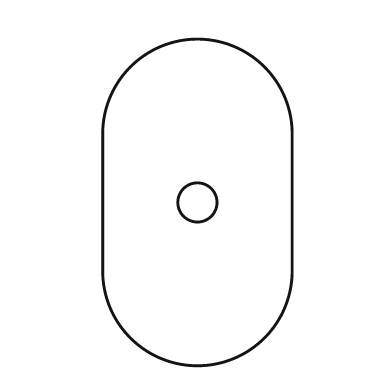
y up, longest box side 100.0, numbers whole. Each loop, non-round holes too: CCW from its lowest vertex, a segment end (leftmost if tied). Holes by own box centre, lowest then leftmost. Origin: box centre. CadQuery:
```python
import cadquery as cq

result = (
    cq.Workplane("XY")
    .moveTo(-29.0, -21.0)
    .threePointArc((0.0, -50.0), (29.0, -21.0))
    .lineTo(29.0, 21.0)
    .threePointArc((0.0, 50.0), (-29.0, 21.0))
    .close()
    .moveTo(0.0, 0.0)
    .circle(6.0)
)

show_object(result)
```